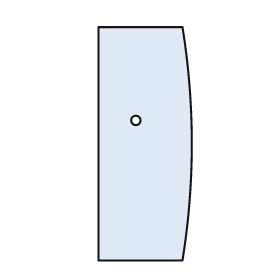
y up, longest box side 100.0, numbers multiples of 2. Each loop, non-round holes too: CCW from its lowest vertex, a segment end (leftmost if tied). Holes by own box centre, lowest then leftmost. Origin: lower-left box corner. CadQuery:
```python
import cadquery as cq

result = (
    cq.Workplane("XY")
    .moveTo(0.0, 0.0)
    .lineTo(36.0, 0.0)
    .threePointArc((40.0, 50.0), (36.0, 100.0))
    .lineTo(0.0, 100.0)
    .close()
    .moveTo(16.0, 60.0)
    .circle(2.0)
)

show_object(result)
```